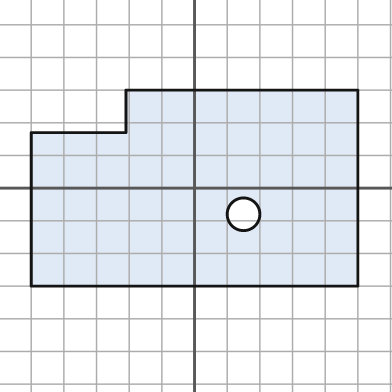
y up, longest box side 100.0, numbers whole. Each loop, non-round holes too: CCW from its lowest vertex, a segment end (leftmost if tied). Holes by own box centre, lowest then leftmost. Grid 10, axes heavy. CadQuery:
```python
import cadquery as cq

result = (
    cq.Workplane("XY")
    .moveTo(-50.0, -30.0)
    .lineTo(50.0, -30.0)
    .lineTo(50.0, 30.0)
    .lineTo(-21.0, 30.0)
    .lineTo(-21.0, 17.0)
    .lineTo(-50.0, 17.0)
    .close()
    .moveTo(15.0, -8.0)
    .circle(5.0)
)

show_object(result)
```